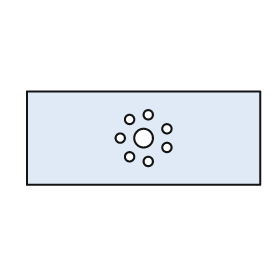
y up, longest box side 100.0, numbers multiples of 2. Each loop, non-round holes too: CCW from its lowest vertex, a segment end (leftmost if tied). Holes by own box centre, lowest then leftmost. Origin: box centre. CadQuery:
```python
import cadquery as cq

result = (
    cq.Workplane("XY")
    .moveTo(-50.0, -20.0)
    .lineTo(50.0, -20.0)
    .lineTo(50.0, 20.0)
    .lineTo(-50.0, 20.0)
    .close()
    .moveTo(2.0, -10.0)
    .circle(2.0)
    .moveTo(-6.0, -8.0)
    .circle(2.0)
    .moveTo(10.0, -4.0)
    .circle(2.0)
    .moveTo(-10.0, 0.0)
    .circle(2.0)
    .moveTo(0.0, 0.0)
    .circle(4.0)
    .moveTo(10.0, 4.0)
    .circle(2.0)
    .moveTo(-6.0, 8.0)
    .circle(2.0)
    .moveTo(2.0, 10.0)
    .circle(2.0)
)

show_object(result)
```